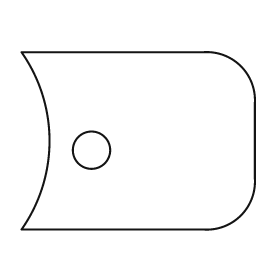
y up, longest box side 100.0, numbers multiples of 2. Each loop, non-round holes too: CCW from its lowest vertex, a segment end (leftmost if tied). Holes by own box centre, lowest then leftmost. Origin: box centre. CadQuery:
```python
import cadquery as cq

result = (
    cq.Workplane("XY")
    .moveTo(-50.0, -38.0)
    .lineTo(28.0, -38.0)
    .threePointArc((44.0, -32.0), (50.0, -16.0))
    .lineTo(50.0, 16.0)
    .threePointArc((44.0, 32.0), (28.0, 38.0))
    .lineTo(-50.0, 38.0)
    .threePointArc((-38.0, 0.0), (-50.0, -38.0))
    .close()
    .moveTo(-20.0, -4.0)
    .circle(8.0)
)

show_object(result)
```